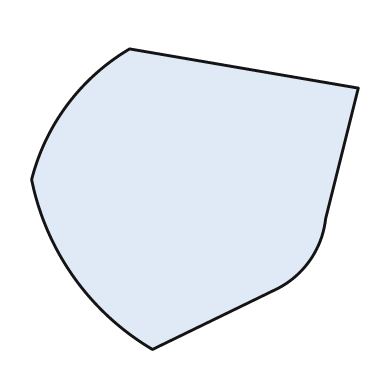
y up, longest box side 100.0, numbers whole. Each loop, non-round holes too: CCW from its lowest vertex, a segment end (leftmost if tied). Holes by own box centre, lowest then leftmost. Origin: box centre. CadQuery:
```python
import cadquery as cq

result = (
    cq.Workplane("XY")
    .moveTo(-13.0, -46.0)
    .lineTo(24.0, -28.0)
    .threePointArc((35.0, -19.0), (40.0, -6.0))
    .lineTo(50.0, 34.0)
    .lineTo(-20.0, 46.0)
    .threePointArc((-39.0, 29.0), (-50.0, 6.0))
    .threePointArc((-37.0, -24.0), (-13.0, -46.0))
    .close()
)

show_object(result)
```